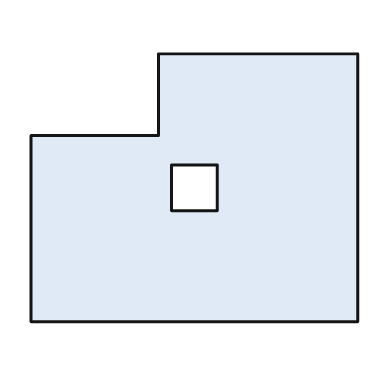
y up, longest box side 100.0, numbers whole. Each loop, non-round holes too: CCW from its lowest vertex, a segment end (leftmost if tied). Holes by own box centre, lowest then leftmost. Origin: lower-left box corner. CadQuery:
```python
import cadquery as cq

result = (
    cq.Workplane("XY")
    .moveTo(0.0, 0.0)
    .lineTo(100.0, 0.0)
    .lineTo(100.0, 82.0)
    .lineTo(39.0, 82.0)
    .lineTo(39.0, 57.0)
    .lineTo(0.0, 57.0)
    .close()
    .moveTo(43.0, 34.0)
    .lineTo(57.0, 34.0)
    .lineTo(57.0, 48.0)
    .lineTo(43.0, 48.0)
    .close()
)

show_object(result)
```